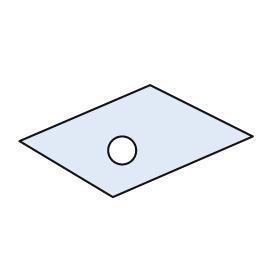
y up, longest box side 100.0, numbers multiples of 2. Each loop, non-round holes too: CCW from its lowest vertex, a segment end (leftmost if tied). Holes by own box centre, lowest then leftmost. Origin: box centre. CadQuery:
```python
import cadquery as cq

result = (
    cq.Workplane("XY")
    .moveTo(-10.0, -24.0)
    .lineTo(50.0, 2.0)
    .lineTo(6.0, 24.0)
    .lineTo(-50.0, 0.0)
    .close()
    .moveTo(-6.0, -4.0)
    .circle(6.0)
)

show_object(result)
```